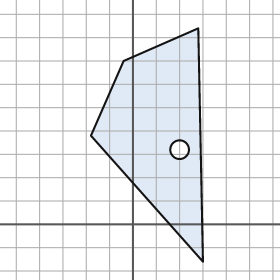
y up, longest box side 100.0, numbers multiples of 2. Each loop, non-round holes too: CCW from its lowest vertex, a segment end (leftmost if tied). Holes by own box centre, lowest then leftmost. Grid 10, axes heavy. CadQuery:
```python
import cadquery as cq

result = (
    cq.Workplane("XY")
    .moveTo(30.0, -16.0)
    .lineTo(28.0, 84.0)
    .lineTo(-4.0, 70.0)
    .lineTo(-18.0, 38.0)
    .close()
    .moveTo(20.0, 32.0)
    .circle(4.0)
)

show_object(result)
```